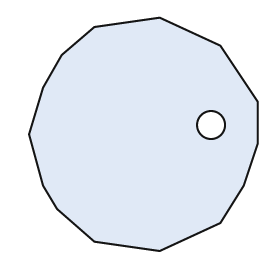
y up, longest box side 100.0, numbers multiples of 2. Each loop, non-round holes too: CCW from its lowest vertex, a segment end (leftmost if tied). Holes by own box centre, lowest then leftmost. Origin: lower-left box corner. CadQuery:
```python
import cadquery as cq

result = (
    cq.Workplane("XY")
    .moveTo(56.0, 0.0)
    .lineTo(82.0, 12.0)
    .lineTo(92.0, 28.0)
    .lineTo(98.0, 46.0)
    .lineTo(98.0, 64.0)
    .lineTo(82.0, 88.0)
    .lineTo(56.0, 100.0)
    .lineTo(28.0, 96.0)
    .lineTo(14.0, 84.0)
    .lineTo(6.0, 70.0)
    .lineTo(0.0, 50.0)
    .lineTo(6.0, 28.0)
    .lineTo(12.0, 18.0)
    .lineTo(28.0, 4.0)
    .close()
    .moveTo(78.0, 54.0)
    .circle(6.0)
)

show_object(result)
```